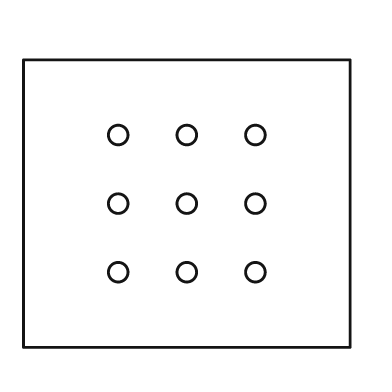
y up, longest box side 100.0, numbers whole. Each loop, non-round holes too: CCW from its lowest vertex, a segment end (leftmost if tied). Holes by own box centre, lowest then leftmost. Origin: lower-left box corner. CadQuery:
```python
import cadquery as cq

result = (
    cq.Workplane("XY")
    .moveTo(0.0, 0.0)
    .lineTo(100.0, 0.0)
    .lineTo(100.0, 88.0)
    .lineTo(0.0, 88.0)
    .close()
    .moveTo(29.0, 23.0)
    .circle(3.0)
    .moveTo(50.0, 23.0)
    .circle(3.0)
    .moveTo(71.0, 23.0)
    .circle(3.0)
    .moveTo(29.0, 44.0)
    .circle(3.0)
    .moveTo(50.0, 44.0)
    .circle(3.0)
    .moveTo(71.0, 44.0)
    .circle(3.0)
    .moveTo(29.0, 65.0)
    .circle(3.0)
    .moveTo(50.0, 65.0)
    .circle(3.0)
    .moveTo(71.0, 65.0)
    .circle(3.0)
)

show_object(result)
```